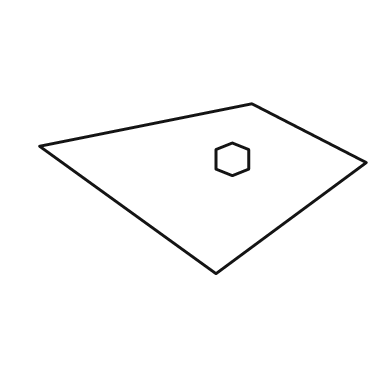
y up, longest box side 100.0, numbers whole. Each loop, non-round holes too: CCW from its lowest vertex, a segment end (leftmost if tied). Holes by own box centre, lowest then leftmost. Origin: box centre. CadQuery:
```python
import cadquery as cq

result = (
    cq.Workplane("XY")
    .moveTo(4.0, -26.0)
    .lineTo(50.0, 8.0)
    .lineTo(15.0, 26.0)
    .lineTo(-50.0, 13.0)
    .close()
    .moveTo(9.0, 4.0)
    .lineTo(14.0, 6.0)
    .lineTo(14.0, 12.0)
    .lineTo(9.0, 14.0)
    .lineTo(4.0, 12.0)
    .lineTo(4.0, 6.0)
    .close()
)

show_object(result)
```